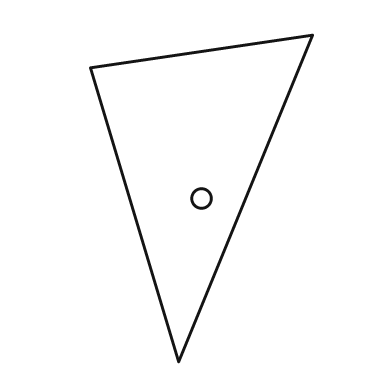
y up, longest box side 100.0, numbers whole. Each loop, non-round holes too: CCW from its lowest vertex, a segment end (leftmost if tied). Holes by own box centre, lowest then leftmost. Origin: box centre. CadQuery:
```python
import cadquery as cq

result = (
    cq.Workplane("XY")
    .moveTo(-7.0, -50.0)
    .lineTo(34.0, 50.0)
    .lineTo(-34.0, 40.0)
    .close()
    .moveTo(0.0, 0.0)
    .circle(3.0)
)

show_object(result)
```